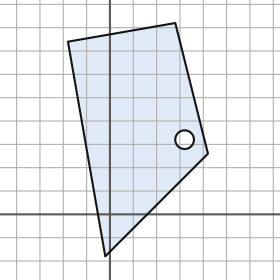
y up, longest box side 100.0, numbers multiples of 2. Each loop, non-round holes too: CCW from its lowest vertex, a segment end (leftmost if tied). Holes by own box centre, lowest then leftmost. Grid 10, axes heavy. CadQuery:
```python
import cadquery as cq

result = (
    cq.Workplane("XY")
    .moveTo(-2.0, -18.0)
    .lineTo(42.0, 26.0)
    .lineTo(28.0, 82.0)
    .lineTo(-18.0, 74.0)
    .close()
    .moveTo(32.0, 32.0)
    .circle(4.0)
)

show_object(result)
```